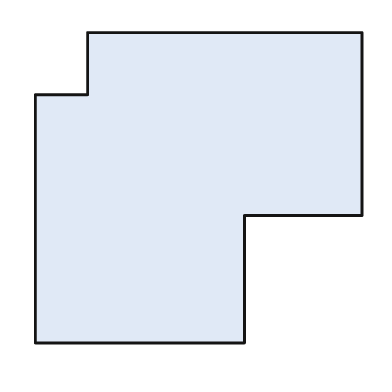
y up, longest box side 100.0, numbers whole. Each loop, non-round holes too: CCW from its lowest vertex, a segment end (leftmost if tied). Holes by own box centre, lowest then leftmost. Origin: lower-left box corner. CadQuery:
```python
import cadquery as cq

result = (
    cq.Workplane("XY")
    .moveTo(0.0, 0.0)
    .lineTo(64.0, 0.0)
    .lineTo(64.0, 39.0)
    .lineTo(100.0, 39.0)
    .lineTo(100.0, 95.0)
    .lineTo(16.0, 95.0)
    .lineTo(16.0, 76.0)
    .lineTo(0.0, 76.0)
    .close()
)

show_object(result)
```